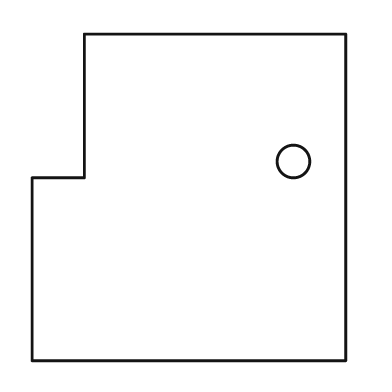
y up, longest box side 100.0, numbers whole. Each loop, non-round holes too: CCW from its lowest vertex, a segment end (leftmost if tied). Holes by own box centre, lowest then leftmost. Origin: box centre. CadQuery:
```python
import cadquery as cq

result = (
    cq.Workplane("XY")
    .moveTo(-48.0, -50.0)
    .lineTo(48.0, -50.0)
    .lineTo(48.0, 50.0)
    .lineTo(-32.0, 50.0)
    .lineTo(-32.0, 6.0)
    .lineTo(-48.0, 6.0)
    .close()
    .moveTo(32.0, 11.0)
    .circle(5.0)
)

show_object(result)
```